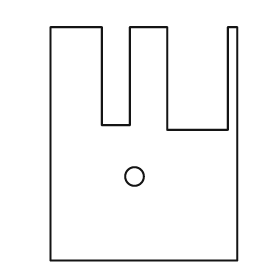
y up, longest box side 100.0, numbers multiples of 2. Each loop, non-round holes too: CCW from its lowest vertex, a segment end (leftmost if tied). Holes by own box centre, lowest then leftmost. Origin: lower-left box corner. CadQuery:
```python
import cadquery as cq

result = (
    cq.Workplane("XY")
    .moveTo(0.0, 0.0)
    .lineTo(80.0, 0.0)
    .lineTo(80.0, 100.0)
    .lineTo(76.0, 100.0)
    .lineTo(76.0, 56.0)
    .lineTo(50.0, 56.0)
    .lineTo(50.0, 100.0)
    .lineTo(34.0, 100.0)
    .lineTo(34.0, 58.0)
    .lineTo(22.0, 58.0)
    .lineTo(22.0, 100.0)
    .lineTo(0.0, 100.0)
    .close()
    .moveTo(36.0, 36.0)
    .circle(4.0)
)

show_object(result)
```